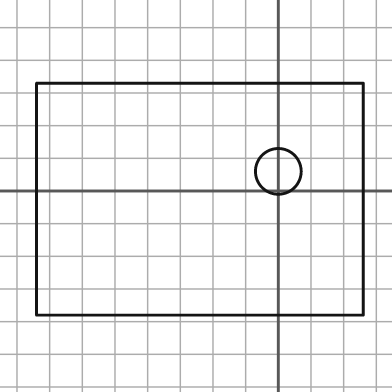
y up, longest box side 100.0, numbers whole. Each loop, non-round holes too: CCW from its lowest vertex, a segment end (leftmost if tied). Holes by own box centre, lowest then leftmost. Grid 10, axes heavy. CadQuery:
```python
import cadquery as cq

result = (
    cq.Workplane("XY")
    .moveTo(-74.0, -38.0)
    .lineTo(26.0, -38.0)
    .lineTo(26.0, 33.0)
    .lineTo(-74.0, 33.0)
    .close()
    .moveTo(0.0, 6.0)
    .circle(7.0)
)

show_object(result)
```